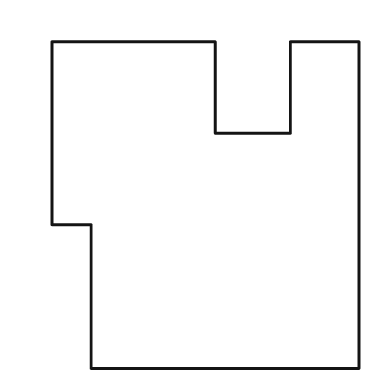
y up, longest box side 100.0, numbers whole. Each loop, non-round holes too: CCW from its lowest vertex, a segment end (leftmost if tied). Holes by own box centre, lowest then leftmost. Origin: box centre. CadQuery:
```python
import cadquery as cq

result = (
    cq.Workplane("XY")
    .moveTo(-35.0, -50.0)
    .lineTo(47.0, -50.0)
    .lineTo(47.0, 50.0)
    .lineTo(26.0, 50.0)
    .lineTo(26.0, 22.0)
    .lineTo(3.0, 22.0)
    .lineTo(3.0, 50.0)
    .lineTo(-47.0, 50.0)
    .lineTo(-47.0, -6.0)
    .lineTo(-35.0, -6.0)
    .close()
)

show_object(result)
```